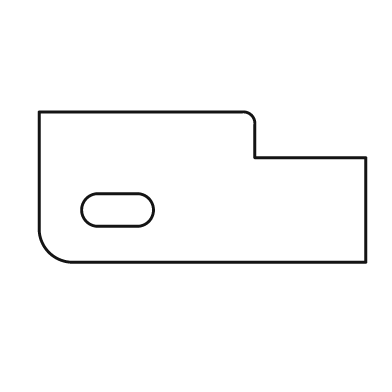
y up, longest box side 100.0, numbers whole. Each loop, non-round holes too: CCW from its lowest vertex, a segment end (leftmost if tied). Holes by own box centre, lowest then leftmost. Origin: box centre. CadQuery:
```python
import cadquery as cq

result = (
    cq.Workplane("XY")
    .moveTo(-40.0, -23.0)
    .lineTo(50.0, -23.0)
    .lineTo(50.0, 9.0)
    .lineTo(16.0, 9.0)
    .lineTo(16.0, 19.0)
    .threePointArc((15.0, 22.0), (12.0, 23.0))
    .lineTo(-50.0, 23.0)
    .lineTo(-50.0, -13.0)
    .threePointArc((-47.0, -20.0), (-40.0, -23.0))
    .close()
    .moveTo(-32.0, -12.0)
    .lineTo(-20.0, -12.0)
    .threePointArc((-15.0, -7.0), (-20.0, -2.0))
    .lineTo(-32.0, -2.0)
    .threePointArc((-37.0, -7.0), (-32.0, -12.0))
    .close()
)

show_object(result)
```